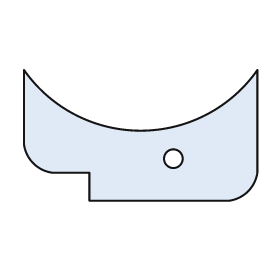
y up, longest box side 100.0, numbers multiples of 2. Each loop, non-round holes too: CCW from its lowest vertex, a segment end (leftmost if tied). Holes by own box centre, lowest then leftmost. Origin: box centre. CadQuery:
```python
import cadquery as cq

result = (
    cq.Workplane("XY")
    .moveTo(-22.0, -28.0)
    .lineTo(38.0, -28.0)
    .threePointArc((46.0, -24.0), (50.0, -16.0))
    .lineTo(50.0, 28.0)
    .threePointArc((0.0, 2.0), (-50.0, 28.0))
    .lineTo(-50.0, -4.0)
    .threePointArc((-46.0, -12.0), (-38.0, -16.0))
    .lineTo(-22.0, -16.0)
    .close()
    .moveTo(14.0, -10.0)
    .circle(4.0)
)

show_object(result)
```